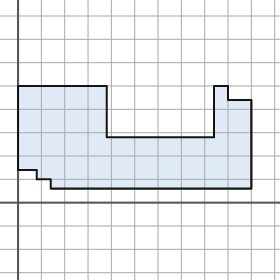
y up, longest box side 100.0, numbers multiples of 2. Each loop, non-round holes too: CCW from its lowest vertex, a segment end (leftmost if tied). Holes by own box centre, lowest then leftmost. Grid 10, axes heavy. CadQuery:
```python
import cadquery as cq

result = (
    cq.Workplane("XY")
    .moveTo(14.0, 6.0)
    .lineTo(100.0, 6.0)
    .lineTo(100.0, 44.0)
    .lineTo(90.0, 44.0)
    .lineTo(90.0, 50.0)
    .lineTo(84.0, 50.0)
    .lineTo(84.0, 28.0)
    .lineTo(38.0, 28.0)
    .lineTo(38.0, 50.0)
    .lineTo(0.0, 50.0)
    .lineTo(0.0, 14.0)
    .lineTo(8.0, 14.0)
    .lineTo(8.0, 10.0)
    .lineTo(14.0, 10.0)
    .close()
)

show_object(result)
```